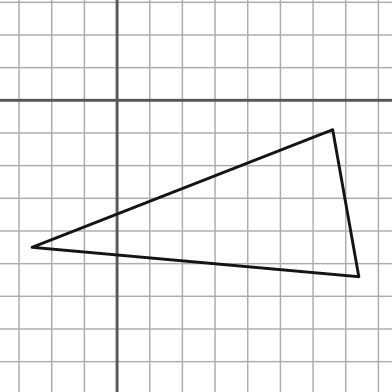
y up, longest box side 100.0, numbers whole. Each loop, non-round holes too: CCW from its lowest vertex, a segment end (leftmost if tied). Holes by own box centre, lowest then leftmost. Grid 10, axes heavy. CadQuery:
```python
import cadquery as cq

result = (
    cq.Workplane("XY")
    .moveTo(74.0, -54.0)
    .lineTo(66.0, -9.0)
    .lineTo(-26.0, -45.0)
    .close()
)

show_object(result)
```